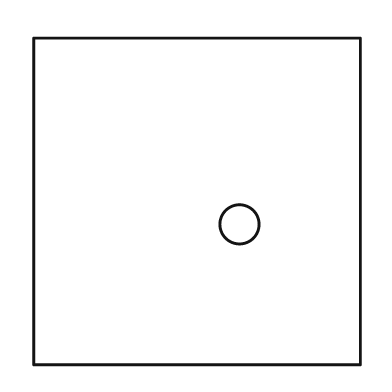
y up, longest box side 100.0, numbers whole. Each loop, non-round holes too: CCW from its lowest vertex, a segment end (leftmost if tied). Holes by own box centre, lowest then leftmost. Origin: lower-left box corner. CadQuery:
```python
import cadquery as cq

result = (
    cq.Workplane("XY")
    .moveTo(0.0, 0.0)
    .lineTo(100.0, 0.0)
    .lineTo(100.0, 100.0)
    .lineTo(0.0, 100.0)
    .close()
    .moveTo(63.0, 43.0)
    .circle(6.0)
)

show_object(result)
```